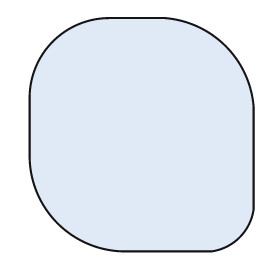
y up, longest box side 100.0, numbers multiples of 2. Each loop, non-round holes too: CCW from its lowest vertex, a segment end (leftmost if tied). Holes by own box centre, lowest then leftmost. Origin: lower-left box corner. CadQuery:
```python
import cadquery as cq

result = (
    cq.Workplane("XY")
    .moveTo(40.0, 0.0)
    .lineTo(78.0, 0.0)
    .threePointArc((90.0, 6.0), (96.0, 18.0))
    .lineTo(96.0, 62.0)
    .threePointArc((84.0, 88.0), (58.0, 100.0))
    .lineTo(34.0, 100.0)
    .threePointArc((10.0, 90.0), (0.0, 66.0))
    .lineTo(0.0, 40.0)
    .threePointArc((12.0, 12.0), (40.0, 0.0))
    .close()
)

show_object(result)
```